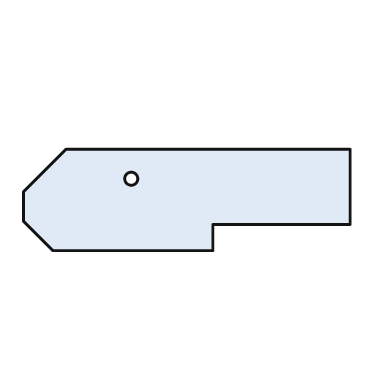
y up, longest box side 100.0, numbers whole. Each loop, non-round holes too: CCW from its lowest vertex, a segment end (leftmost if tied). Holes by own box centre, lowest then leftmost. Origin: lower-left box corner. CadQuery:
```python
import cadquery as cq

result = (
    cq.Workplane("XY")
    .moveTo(9.0, 0.0)
    .lineTo(58.0, 0.0)
    .lineTo(58.0, 8.0)
    .lineTo(100.0, 8.0)
    .lineTo(100.0, 31.0)
    .lineTo(13.0, 31.0)
    .lineTo(0.0, 18.0)
    .lineTo(0.0, 9.0)
    .close()
    .moveTo(33.0, 22.0)
    .circle(2.0)
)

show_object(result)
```